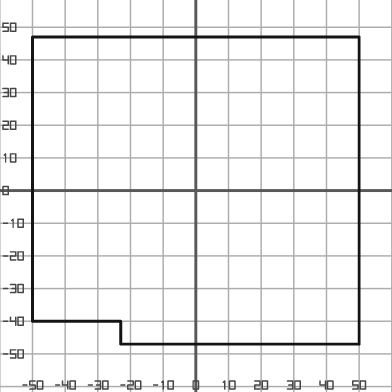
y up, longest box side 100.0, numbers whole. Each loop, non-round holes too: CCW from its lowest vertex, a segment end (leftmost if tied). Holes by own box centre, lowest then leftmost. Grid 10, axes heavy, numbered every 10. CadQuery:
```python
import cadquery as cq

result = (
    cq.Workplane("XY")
    .moveTo(-23.0, -47.0)
    .lineTo(50.0, -47.0)
    .lineTo(50.0, 47.0)
    .lineTo(-50.0, 47.0)
    .lineTo(-50.0, -40.0)
    .lineTo(-23.0, -40.0)
    .close()
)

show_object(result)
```